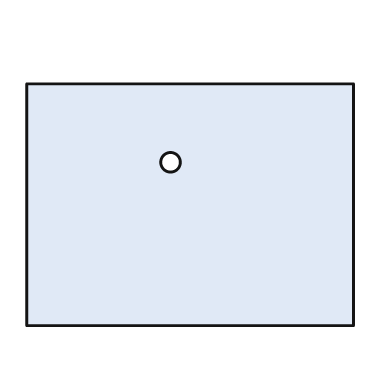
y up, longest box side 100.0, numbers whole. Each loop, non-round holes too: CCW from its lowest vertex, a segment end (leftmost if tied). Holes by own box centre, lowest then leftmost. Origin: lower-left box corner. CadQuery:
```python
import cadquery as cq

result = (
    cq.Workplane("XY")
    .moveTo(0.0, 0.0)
    .lineTo(100.0, 0.0)
    .lineTo(100.0, 74.0)
    .lineTo(0.0, 74.0)
    .close()
    .moveTo(44.0, 50.0)
    .circle(3.0)
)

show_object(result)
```